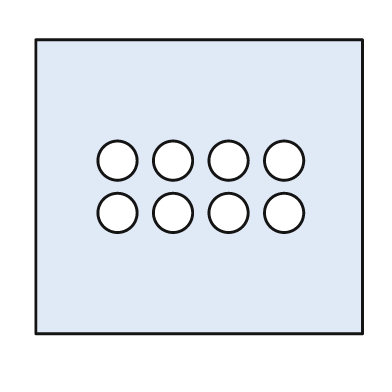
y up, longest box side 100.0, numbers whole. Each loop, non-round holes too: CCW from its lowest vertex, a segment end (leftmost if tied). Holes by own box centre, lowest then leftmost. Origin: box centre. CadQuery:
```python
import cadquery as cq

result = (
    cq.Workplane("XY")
    .moveTo(-50.0, -45.0)
    .lineTo(50.0, -45.0)
    .lineTo(50.0, 45.0)
    .lineTo(-50.0, 45.0)
    .close()
    .moveTo(-25.0, -8.0)
    .circle(6.0)
    .moveTo(-8.0, -8.0)
    .circle(6.0)
    .moveTo(9.0, -8.0)
    .circle(6.0)
    .moveTo(26.0, -8.0)
    .circle(6.0)
    .moveTo(-25.0, 8.0)
    .circle(6.0)
    .moveTo(-8.0, 8.0)
    .circle(6.0)
    .moveTo(9.0, 8.0)
    .circle(6.0)
    .moveTo(26.0, 8.0)
    .circle(6.0)
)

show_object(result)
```